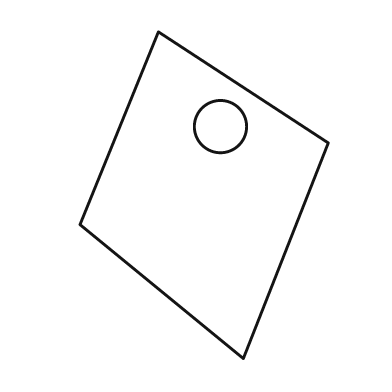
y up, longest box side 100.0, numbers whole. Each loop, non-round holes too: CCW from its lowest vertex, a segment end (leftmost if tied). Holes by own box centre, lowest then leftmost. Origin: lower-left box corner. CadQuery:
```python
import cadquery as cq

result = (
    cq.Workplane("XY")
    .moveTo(50.0, 0.0)
    .lineTo(76.0, 66.0)
    .lineTo(24.0, 100.0)
    .lineTo(0.0, 41.0)
    .close()
    .moveTo(43.0, 71.0)
    .circle(8.0)
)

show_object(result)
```